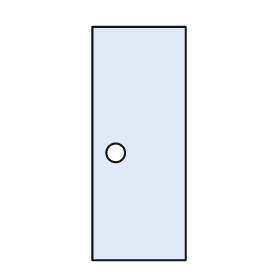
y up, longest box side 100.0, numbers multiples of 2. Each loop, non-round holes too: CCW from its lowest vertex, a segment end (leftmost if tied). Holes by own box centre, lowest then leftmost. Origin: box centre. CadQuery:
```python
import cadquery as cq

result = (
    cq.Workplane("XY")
    .moveTo(-20.0, -50.0)
    .lineTo(20.0, -50.0)
    .lineTo(20.0, 50.0)
    .lineTo(-20.0, 50.0)
    .close()
    .moveTo(-10.0, -4.0)
    .circle(4.0)
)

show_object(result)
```